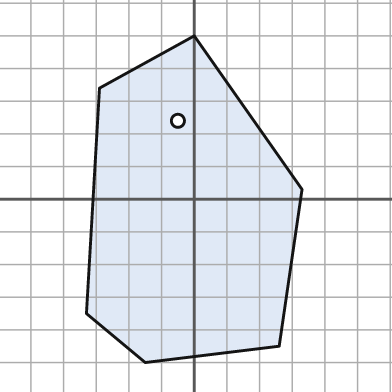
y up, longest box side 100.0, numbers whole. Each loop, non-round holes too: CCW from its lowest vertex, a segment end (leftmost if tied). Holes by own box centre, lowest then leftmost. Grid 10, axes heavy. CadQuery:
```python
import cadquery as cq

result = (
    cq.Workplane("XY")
    .moveTo(-15.0, -50.0)
    .lineTo(26.0, -45.0)
    .lineTo(33.0, 3.0)
    .lineTo(0.0, 50.0)
    .lineTo(-29.0, 34.0)
    .lineTo(-33.0, -35.0)
    .close()
    .moveTo(-5.0, 24.0)
    .circle(2.0)
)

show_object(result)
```